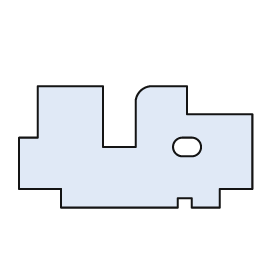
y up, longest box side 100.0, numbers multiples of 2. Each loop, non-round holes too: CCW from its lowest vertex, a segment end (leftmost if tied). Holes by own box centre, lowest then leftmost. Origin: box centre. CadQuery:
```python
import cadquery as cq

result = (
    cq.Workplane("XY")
    .moveTo(-32.0, -26.0)
    .lineTo(18.0, -26.0)
    .lineTo(18.0, -22.0)
    .lineTo(24.0, -22.0)
    .lineTo(24.0, -26.0)
    .lineTo(36.0, -26.0)
    .lineTo(36.0, -18.0)
    .lineTo(50.0, -18.0)
    .lineTo(50.0, 14.0)
    .lineTo(22.0, 14.0)
    .lineTo(22.0, 26.0)
    .lineTo(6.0, 26.0)
    .threePointArc((2.0, 24.0), (0.0, 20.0))
    .lineTo(0.0, 0.0)
    .lineTo(-14.0, 0.0)
    .lineTo(-14.0, 26.0)
    .lineTo(-42.0, 26.0)
    .lineTo(-42.0, 4.0)
    .lineTo(-50.0, 4.0)
    .lineTo(-50.0, -18.0)
    .lineTo(-32.0, -18.0)
    .close()
    .moveTo(20.0, -4.0)
    .lineTo(24.0, -4.0)
    .threePointArc((28.0, 0.0), (24.0, 4.0))
    .lineTo(20.0, 4.0)
    .threePointArc((16.0, 0.0), (20.0, -4.0))
    .close()
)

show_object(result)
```